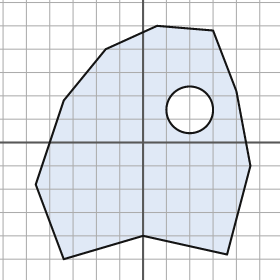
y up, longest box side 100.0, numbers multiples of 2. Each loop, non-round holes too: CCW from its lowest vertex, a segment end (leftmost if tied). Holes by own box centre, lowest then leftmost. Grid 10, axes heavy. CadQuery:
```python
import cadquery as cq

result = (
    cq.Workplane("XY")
    .moveTo(-34.0, -50.0)
    .lineTo(0.0, -40.0)
    .lineTo(36.0, -48.0)
    .lineTo(46.0, -10.0)
    .lineTo(40.0, 22.0)
    .lineTo(30.0, 48.0)
    .lineTo(6.0, 50.0)
    .lineTo(-16.0, 40.0)
    .lineTo(-34.0, 18.0)
    .lineTo(-46.0, -18.0)
    .close()
    .moveTo(20.0, 14.0)
    .circle(10.0)
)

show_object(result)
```